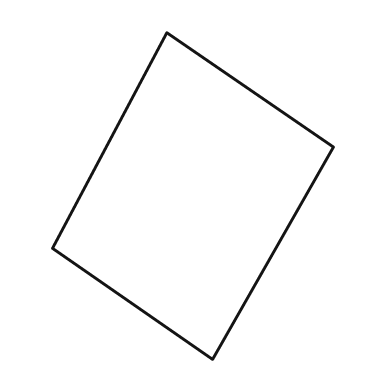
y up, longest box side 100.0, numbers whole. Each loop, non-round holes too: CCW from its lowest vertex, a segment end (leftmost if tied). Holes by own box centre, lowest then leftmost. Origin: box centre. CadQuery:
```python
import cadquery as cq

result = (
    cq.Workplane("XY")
    .moveTo(6.0, -50.0)
    .lineTo(43.0, 15.0)
    .lineTo(-8.0, 50.0)
    .lineTo(-43.0, -16.0)
    .close()
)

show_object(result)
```